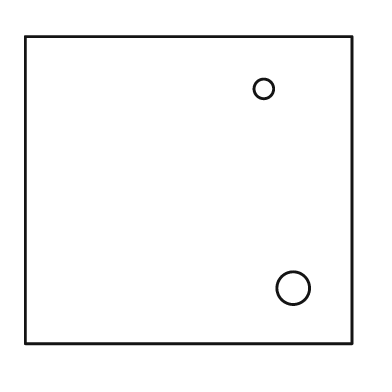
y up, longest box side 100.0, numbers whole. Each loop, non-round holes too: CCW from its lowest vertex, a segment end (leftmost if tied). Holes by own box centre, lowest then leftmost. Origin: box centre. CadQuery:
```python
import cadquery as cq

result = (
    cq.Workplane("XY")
    .moveTo(-50.0, -47.0)
    .lineTo(50.0, -47.0)
    .lineTo(50.0, 47.0)
    .lineTo(-50.0, 47.0)
    .close()
    .moveTo(32.0, -30.0)
    .circle(5.0)
    .moveTo(23.0, 31.0)
    .circle(3.0)
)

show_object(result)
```